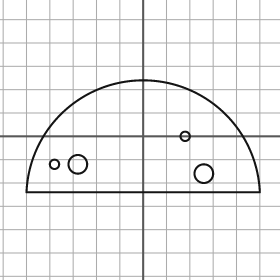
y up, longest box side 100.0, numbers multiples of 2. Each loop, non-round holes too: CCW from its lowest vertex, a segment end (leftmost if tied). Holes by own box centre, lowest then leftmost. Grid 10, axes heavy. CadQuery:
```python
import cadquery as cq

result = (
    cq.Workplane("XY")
    .moveTo(-50.0, -24.0)
    .lineTo(50.0, -24.0)
    .threePointArc((0.0, 24.0), (-50.0, -24.0))
    .close()
    .moveTo(26.0, -16.0)
    .circle(4.0)
    .moveTo(-38.0, -12.0)
    .circle(2.0)
    .moveTo(-28.0, -12.0)
    .circle(4.0)
    .moveTo(18.0, 0.0)
    .circle(2.0)
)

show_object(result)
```